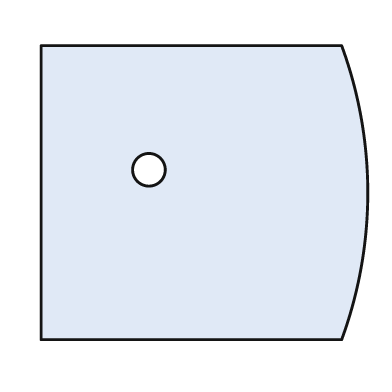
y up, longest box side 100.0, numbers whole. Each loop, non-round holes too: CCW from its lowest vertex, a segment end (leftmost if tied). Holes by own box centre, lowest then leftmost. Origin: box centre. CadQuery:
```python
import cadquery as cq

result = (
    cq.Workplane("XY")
    .moveTo(-50.0, -45.0)
    .lineTo(42.0, -45.0)
    .threePointArc((50.0, 0.0), (42.0, 45.0))
    .lineTo(-50.0, 45.0)
    .close()
    .moveTo(-17.0, 7.0)
    .circle(5.0)
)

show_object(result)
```